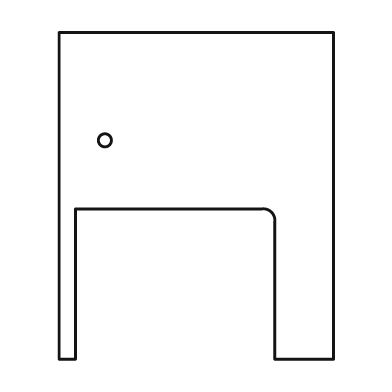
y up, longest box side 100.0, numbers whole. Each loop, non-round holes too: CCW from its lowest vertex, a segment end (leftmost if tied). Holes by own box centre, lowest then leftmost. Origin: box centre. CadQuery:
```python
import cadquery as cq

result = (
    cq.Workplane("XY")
    .moveTo(-42.0, -50.0)
    .lineTo(-37.0, -50.0)
    .lineTo(-37.0, -4.0)
    .lineTo(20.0, -4.0)
    .threePointArc((23.0, -5.0), (24.0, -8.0))
    .lineTo(24.0, -50.0)
    .lineTo(42.0, -50.0)
    .lineTo(42.0, 50.0)
    .lineTo(-42.0, 50.0)
    .close()
    .moveTo(-28.0, 17.0)
    .circle(2.0)
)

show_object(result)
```